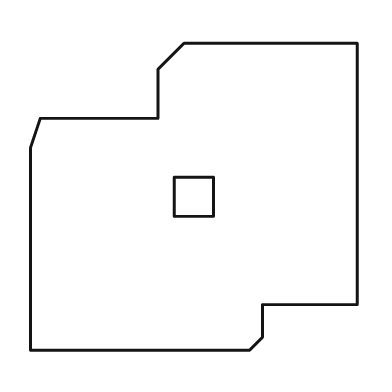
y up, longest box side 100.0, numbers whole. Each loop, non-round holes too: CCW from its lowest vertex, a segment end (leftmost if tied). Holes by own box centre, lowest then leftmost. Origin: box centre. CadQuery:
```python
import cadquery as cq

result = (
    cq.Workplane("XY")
    .moveTo(-50.0, -47.0)
    .lineTo(17.0, -47.0)
    .lineTo(21.0, -43.0)
    .lineTo(21.0, -33.0)
    .lineTo(50.0, -33.0)
    .lineTo(50.0, 47.0)
    .lineTo(-3.0, 47.0)
    .lineTo(-11.0, 39.0)
    .lineTo(-11.0, 24.0)
    .lineTo(-47.0, 24.0)
    .lineTo(-50.0, 15.0)
    .close()
    .moveTo(-6.0, -6.0)
    .lineTo(6.0, -6.0)
    .lineTo(6.0, 6.0)
    .lineTo(-6.0, 6.0)
    .close()
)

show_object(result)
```